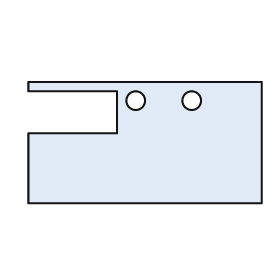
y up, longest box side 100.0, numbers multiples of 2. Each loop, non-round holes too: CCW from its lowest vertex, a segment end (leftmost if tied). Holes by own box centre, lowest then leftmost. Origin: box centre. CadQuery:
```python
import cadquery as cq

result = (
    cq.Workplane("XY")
    .moveTo(-50.0, -26.0)
    .lineTo(50.0, -26.0)
    .lineTo(50.0, 26.0)
    .lineTo(-50.0, 26.0)
    .lineTo(-50.0, 22.0)
    .lineTo(-12.0, 22.0)
    .lineTo(-12.0, 4.0)
    .lineTo(-50.0, 4.0)
    .close()
    .moveTo(-4.0, 18.0)
    .circle(4.0)
    .moveTo(20.0, 18.0)
    .circle(4.0)
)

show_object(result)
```